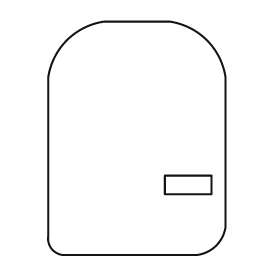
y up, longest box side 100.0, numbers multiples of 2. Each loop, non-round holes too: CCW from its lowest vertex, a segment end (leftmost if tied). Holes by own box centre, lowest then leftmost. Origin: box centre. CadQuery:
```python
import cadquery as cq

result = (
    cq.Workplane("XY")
    .moveTo(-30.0, -50.0)
    .lineTo(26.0, -50.0)
    .threePointArc((34.0, -46.0), (38.0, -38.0))
    .lineTo(38.0, 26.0)
    .threePointArc((30.0, 42.0), (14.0, 50.0))
    .lineTo(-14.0, 50.0)
    .threePointArc((-30.0, 42.0), (-38.0, 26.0))
    .lineTo(-38.0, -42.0)
    .threePointArc((-36.0, -48.0), (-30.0, -50.0))
    .close()
    .moveTo(12.0, -24.0)
    .lineTo(32.0, -24.0)
    .lineTo(32.0, -16.0)
    .lineTo(12.0, -16.0)
    .close()
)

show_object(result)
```